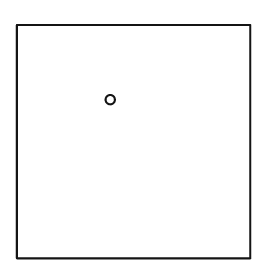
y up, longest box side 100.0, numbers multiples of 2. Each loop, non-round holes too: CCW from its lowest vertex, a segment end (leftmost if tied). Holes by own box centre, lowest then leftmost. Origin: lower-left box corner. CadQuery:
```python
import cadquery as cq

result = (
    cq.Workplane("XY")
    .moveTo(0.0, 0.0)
    .lineTo(100.0, 0.0)
    .lineTo(100.0, 100.0)
    .lineTo(0.0, 100.0)
    .close()
    .moveTo(40.0, 68.0)
    .circle(2.0)
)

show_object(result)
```